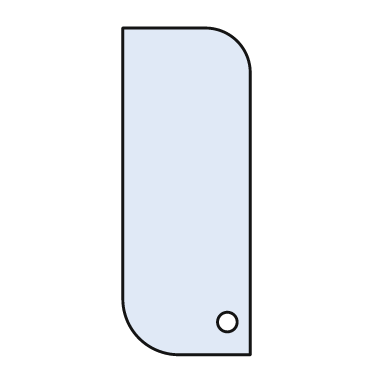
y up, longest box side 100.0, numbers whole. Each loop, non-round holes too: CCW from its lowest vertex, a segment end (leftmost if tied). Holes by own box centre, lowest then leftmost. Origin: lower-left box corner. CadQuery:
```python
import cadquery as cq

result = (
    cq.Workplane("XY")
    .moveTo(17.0, 0.0)
    .lineTo(39.0, 0.0)
    .lineTo(39.0, 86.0)
    .threePointArc((35.0, 96.0), (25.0, 100.0))
    .lineTo(0.0, 100.0)
    .lineTo(0.0, 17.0)
    .threePointArc((5.0, 5.0), (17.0, 0.0))
    .close()
    .moveTo(32.0, 10.0)
    .circle(3.0)
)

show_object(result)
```